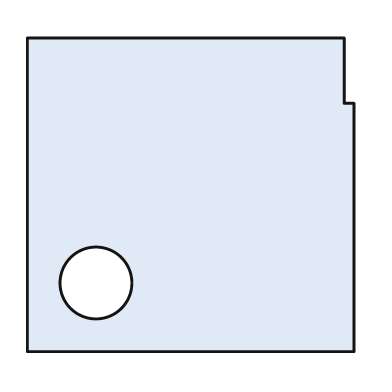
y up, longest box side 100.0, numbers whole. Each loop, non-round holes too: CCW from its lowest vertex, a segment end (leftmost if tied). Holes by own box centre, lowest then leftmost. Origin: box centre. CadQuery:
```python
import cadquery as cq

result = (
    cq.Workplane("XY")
    .moveTo(-50.0, -48.0)
    .lineTo(50.0, -48.0)
    .lineTo(50.0, 28.0)
    .lineTo(47.0, 28.0)
    .lineTo(47.0, 48.0)
    .lineTo(-50.0, 48.0)
    .close()
    .moveTo(-29.0, -27.0)
    .circle(11.0)
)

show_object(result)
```